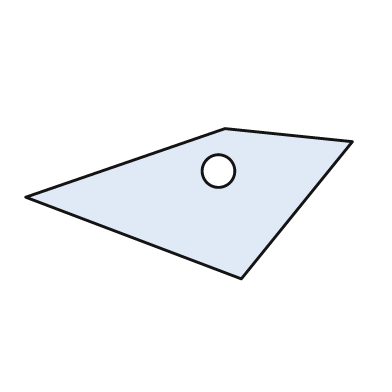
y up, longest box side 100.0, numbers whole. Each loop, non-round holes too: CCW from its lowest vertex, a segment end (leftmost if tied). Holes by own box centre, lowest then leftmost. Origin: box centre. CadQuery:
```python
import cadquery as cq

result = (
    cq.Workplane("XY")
    .moveTo(16.0, -23.0)
    .lineTo(50.0, 19.0)
    .lineTo(11.0, 23.0)
    .lineTo(-50.0, 2.0)
    .close()
    .moveTo(9.0, 10.0)
    .circle(5.0)
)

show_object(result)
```